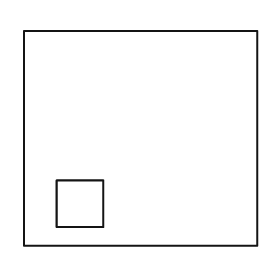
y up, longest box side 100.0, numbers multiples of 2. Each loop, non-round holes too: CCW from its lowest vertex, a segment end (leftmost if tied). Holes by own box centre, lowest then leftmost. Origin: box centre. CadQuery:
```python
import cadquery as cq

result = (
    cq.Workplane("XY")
    .moveTo(-50.0, -46.0)
    .lineTo(50.0, -46.0)
    .lineTo(50.0, 46.0)
    .lineTo(-50.0, 46.0)
    .close()
    .moveTo(-36.0, -38.0)
    .lineTo(-16.0, -38.0)
    .lineTo(-16.0, -18.0)
    .lineTo(-36.0, -18.0)
    .close()
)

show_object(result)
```